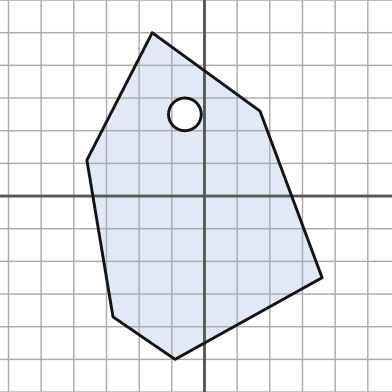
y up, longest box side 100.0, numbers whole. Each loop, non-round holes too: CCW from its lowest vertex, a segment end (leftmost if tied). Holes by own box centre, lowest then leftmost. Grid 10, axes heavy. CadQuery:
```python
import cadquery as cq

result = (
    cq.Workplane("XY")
    .moveTo(-9.0, -50.0)
    .lineTo(36.0, -25.0)
    .lineTo(17.0, 26.0)
    .lineTo(-16.0, 50.0)
    .lineTo(-36.0, 11.0)
    .lineTo(-28.0, -37.0)
    .close()
    .moveTo(-6.0, 25.0)
    .circle(5.0)
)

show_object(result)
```